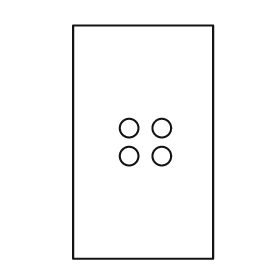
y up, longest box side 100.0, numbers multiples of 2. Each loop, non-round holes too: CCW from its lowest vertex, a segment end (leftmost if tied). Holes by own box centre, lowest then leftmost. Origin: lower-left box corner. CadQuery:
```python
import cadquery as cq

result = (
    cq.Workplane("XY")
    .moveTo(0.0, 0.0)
    .lineTo(60.0, 0.0)
    .lineTo(60.0, 100.0)
    .lineTo(0.0, 100.0)
    .close()
    .moveTo(24.0, 44.0)
    .circle(4.0)
    .moveTo(38.0, 44.0)
    .circle(4.0)
    .moveTo(24.0, 56.0)
    .circle(4.0)
    .moveTo(38.0, 56.0)
    .circle(4.0)
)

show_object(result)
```